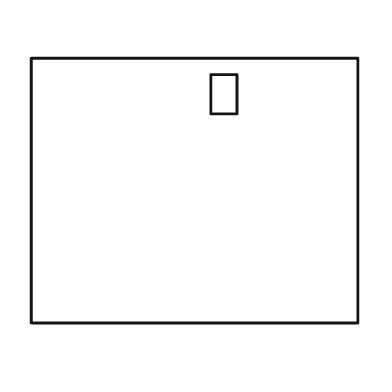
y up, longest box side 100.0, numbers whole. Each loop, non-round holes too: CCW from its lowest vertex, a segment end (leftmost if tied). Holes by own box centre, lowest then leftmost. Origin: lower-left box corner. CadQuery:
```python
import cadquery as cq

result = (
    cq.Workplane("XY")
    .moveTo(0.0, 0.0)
    .lineTo(100.0, 0.0)
    .lineTo(100.0, 81.0)
    .lineTo(0.0, 81.0)
    .close()
    .moveTo(55.0, 64.0)
    .lineTo(63.0, 64.0)
    .lineTo(63.0, 76.0)
    .lineTo(55.0, 76.0)
    .close()
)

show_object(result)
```